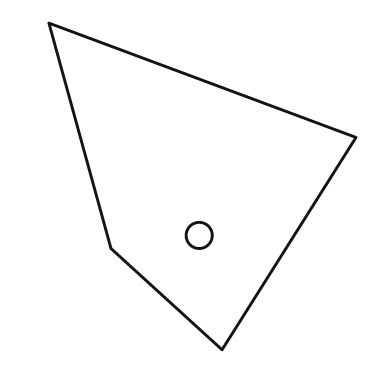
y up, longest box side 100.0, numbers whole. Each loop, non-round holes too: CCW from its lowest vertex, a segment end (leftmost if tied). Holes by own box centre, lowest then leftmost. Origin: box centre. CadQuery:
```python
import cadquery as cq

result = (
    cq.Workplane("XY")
    .moveTo(6.0, -50.0)
    .lineTo(47.0, 15.0)
    .lineTo(-47.0, 50.0)
    .lineTo(-28.0, -19.0)
    .close()
    .moveTo(-1.0, -15.0)
    .circle(4.0)
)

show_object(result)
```